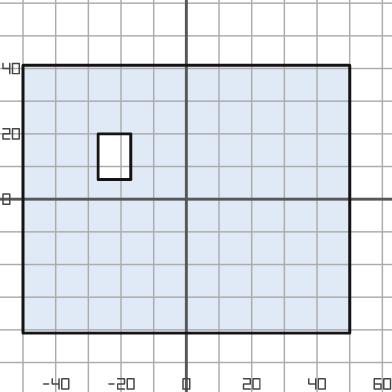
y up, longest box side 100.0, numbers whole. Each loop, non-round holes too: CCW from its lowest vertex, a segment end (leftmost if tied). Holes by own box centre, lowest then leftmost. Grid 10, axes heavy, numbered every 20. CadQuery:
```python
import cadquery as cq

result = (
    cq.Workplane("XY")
    .moveTo(-50.0, -41.0)
    .lineTo(50.0, -41.0)
    .lineTo(50.0, 41.0)
    .lineTo(-50.0, 41.0)
    .close()
    .moveTo(-27.0, 6.0)
    .lineTo(-17.0, 6.0)
    .lineTo(-17.0, 20.0)
    .lineTo(-27.0, 20.0)
    .close()
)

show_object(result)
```